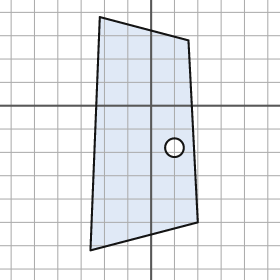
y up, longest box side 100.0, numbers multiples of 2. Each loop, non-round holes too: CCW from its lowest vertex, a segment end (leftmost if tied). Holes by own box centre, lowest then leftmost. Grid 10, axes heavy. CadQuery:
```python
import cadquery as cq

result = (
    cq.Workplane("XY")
    .moveTo(-26.0, -62.0)
    .lineTo(20.0, -50.0)
    .lineTo(16.0, 28.0)
    .lineTo(-22.0, 38.0)
    .close()
    .moveTo(10.0, -18.0)
    .circle(4.0)
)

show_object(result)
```